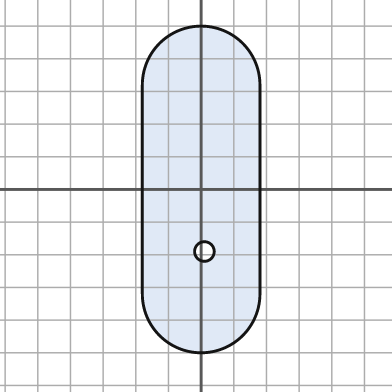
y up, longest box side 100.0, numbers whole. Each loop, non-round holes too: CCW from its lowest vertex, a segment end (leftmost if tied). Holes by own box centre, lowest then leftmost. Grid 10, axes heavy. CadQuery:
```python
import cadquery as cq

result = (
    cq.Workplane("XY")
    .moveTo(-18.0, -32.0)
    .threePointArc((0.0, -50.0), (18.0, -32.0))
    .lineTo(18.0, 32.0)
    .threePointArc((0.0, 50.0), (-18.0, 32.0))
    .close()
    .moveTo(1.0, -19.0)
    .circle(3.0)
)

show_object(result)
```